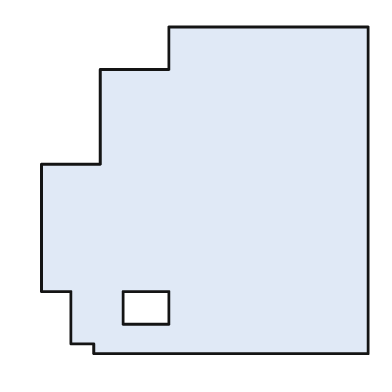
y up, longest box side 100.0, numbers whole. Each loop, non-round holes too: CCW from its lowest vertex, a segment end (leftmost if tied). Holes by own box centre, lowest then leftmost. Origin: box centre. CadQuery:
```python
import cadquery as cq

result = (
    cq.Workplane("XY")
    .moveTo(-34.0, -50.0)
    .lineTo(50.0, -50.0)
    .lineTo(50.0, 50.0)
    .lineTo(-11.0, 50.0)
    .lineTo(-11.0, 37.0)
    .lineTo(-32.0, 37.0)
    .lineTo(-32.0, 8.0)
    .lineTo(-50.0, 8.0)
    .lineTo(-50.0, -31.0)
    .lineTo(-41.0, -31.0)
    .lineTo(-41.0, -47.0)
    .lineTo(-34.0, -47.0)
    .close()
    .moveTo(-25.0, -41.0)
    .lineTo(-11.0, -41.0)
    .lineTo(-11.0, -31.0)
    .lineTo(-25.0, -31.0)
    .close()
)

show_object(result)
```